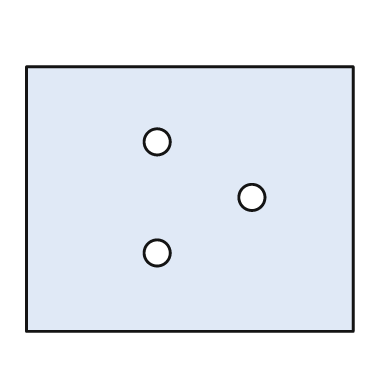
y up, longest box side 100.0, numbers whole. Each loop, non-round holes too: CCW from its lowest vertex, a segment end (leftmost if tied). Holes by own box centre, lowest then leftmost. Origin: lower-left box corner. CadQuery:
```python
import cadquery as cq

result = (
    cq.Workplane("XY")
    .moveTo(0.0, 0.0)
    .lineTo(100.0, 0.0)
    .lineTo(100.0, 81.0)
    .lineTo(0.0, 81.0)
    .close()
    .moveTo(40.0, 24.0)
    .circle(4.0)
    .moveTo(69.0, 41.0)
    .circle(4.0)
    .moveTo(40.0, 58.0)
    .circle(4.0)
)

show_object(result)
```